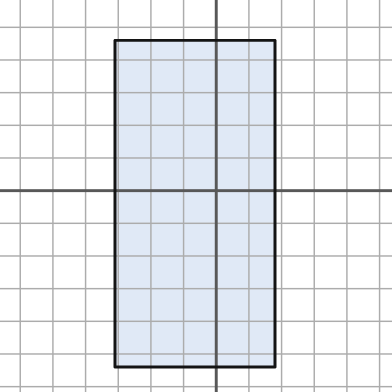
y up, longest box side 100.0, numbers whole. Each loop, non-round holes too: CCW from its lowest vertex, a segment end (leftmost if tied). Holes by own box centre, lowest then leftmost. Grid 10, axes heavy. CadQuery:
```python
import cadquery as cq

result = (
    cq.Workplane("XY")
    .moveTo(-31.0, -54.0)
    .lineTo(18.0, -54.0)
    .lineTo(18.0, 46.0)
    .lineTo(-31.0, 46.0)
    .close()
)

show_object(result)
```